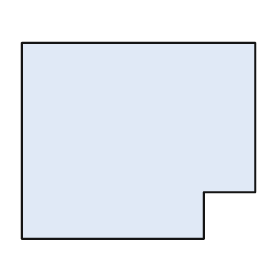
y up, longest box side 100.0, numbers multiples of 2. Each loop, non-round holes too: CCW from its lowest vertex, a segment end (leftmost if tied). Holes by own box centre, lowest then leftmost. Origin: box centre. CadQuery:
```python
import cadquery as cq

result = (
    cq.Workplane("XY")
    .moveTo(-50.0, -42.0)
    .lineTo(28.0, -42.0)
    .lineTo(28.0, -22.0)
    .lineTo(50.0, -22.0)
    .lineTo(50.0, 42.0)
    .lineTo(-50.0, 42.0)
    .close()
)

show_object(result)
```